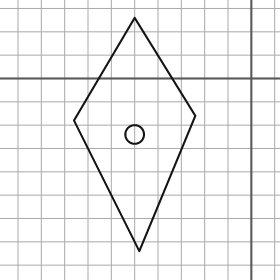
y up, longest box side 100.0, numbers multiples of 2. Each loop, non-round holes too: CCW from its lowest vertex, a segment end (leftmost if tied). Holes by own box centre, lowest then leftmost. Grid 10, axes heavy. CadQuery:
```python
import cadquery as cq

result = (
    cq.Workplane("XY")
    .moveTo(-48.0, -74.0)
    .lineTo(-24.0, -16.0)
    .lineTo(-50.0, 26.0)
    .lineTo(-76.0, -18.0)
    .close()
    .moveTo(-50.0, -24.0)
    .circle(4.0)
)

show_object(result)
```